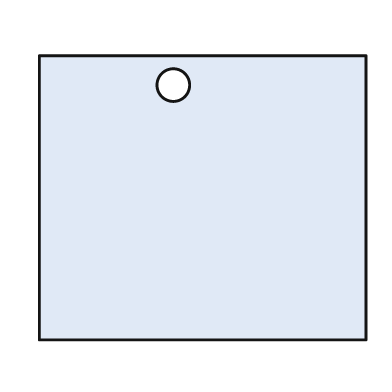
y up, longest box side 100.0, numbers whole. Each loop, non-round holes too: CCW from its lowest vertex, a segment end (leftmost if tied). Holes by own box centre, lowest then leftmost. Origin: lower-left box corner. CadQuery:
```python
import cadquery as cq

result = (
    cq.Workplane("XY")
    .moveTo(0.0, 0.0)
    .lineTo(100.0, 0.0)
    .lineTo(100.0, 87.0)
    .lineTo(0.0, 87.0)
    .close()
    .moveTo(41.0, 78.0)
    .circle(5.0)
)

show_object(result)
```